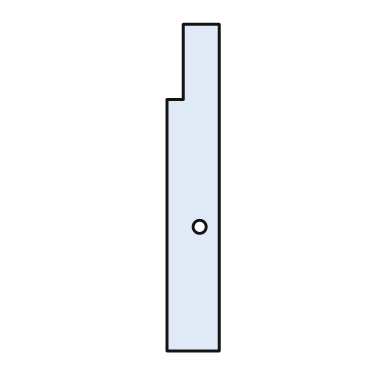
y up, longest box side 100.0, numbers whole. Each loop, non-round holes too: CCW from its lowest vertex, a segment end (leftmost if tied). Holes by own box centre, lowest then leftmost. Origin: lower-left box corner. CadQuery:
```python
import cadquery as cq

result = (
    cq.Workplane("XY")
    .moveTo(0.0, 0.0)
    .lineTo(16.0, 0.0)
    .lineTo(16.0, 100.0)
    .lineTo(5.0, 100.0)
    .lineTo(5.0, 77.0)
    .lineTo(0.0, 77.0)
    .close()
    .moveTo(10.0, 38.0)
    .circle(2.0)
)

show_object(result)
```